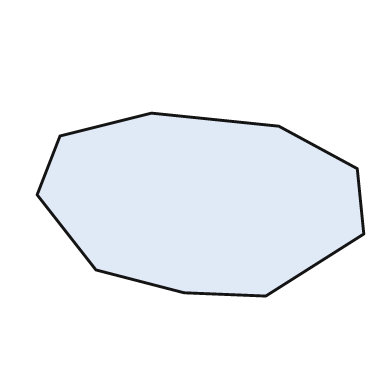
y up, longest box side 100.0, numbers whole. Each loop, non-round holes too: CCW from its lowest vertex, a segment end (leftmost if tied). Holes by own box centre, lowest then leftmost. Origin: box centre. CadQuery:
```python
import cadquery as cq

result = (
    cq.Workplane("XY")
    .moveTo(20.0, -28.0)
    .lineTo(50.0, -9.0)
    .lineTo(48.0, 11.0)
    .lineTo(24.0, 24.0)
    .lineTo(-15.0, 28.0)
    .lineTo(-43.0, 21.0)
    .lineTo(-50.0, 3.0)
    .lineTo(-32.0, -20.0)
    .lineTo(-5.0, -27.0)
    .close()
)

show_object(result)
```